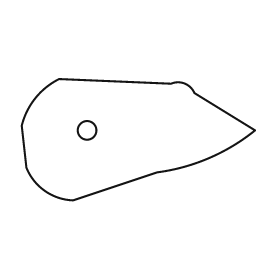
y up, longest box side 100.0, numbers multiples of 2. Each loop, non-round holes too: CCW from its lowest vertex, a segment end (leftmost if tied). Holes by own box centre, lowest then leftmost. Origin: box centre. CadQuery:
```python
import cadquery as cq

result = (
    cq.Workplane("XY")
    .moveTo(-28.0, -26.0)
    .lineTo(8.0, -14.0)
    .threePointArc((30.0, -8.0), (50.0, 4.0))
    .lineTo(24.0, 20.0)
    .threePointArc((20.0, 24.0), (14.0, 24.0))
    .lineTo(-34.0, 26.0)
    .threePointArc((-44.0, 18.0), (-50.0, 6.0))
    .lineTo(-48.0, -12.0)
    .threePointArc((-40.0, -22.0), (-28.0, -26.0))
    .close()
    .moveTo(-22.0, 4.0)
    .circle(4.0)
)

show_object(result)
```